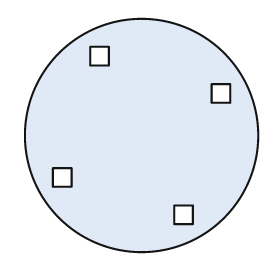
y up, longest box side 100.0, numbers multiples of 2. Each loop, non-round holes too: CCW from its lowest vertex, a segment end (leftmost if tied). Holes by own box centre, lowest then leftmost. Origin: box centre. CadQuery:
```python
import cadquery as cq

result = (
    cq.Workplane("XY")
    .moveTo(0.0, 0.0)
    .circle(50.0)
    .moveTo(14.0, -38.0)
    .lineTo(22.0, -38.0)
    .lineTo(22.0, -30.0)
    .lineTo(14.0, -30.0)
    .close()
    .moveTo(-38.0, -22.0)
    .lineTo(-30.0, -22.0)
    .lineTo(-30.0, -14.0)
    .lineTo(-38.0, -14.0)
    .close()
    .moveTo(30.0, 14.0)
    .lineTo(38.0, 14.0)
    .lineTo(38.0, 22.0)
    .lineTo(30.0, 22.0)
    .close()
    .moveTo(-22.0, 30.0)
    .lineTo(-14.0, 30.0)
    .lineTo(-14.0, 38.0)
    .lineTo(-22.0, 38.0)
    .close()
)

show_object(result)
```